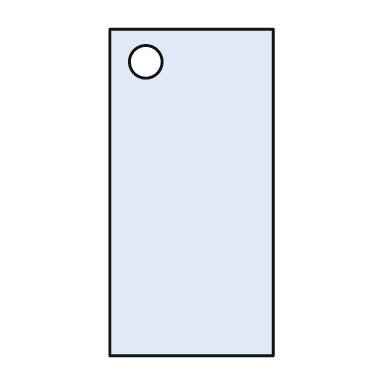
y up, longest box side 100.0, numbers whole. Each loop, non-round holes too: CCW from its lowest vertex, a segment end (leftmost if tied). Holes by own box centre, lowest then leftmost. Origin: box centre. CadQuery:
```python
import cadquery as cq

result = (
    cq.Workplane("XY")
    .moveTo(-25.0, -50.0)
    .lineTo(25.0, -50.0)
    .lineTo(25.0, 50.0)
    .lineTo(-25.0, 50.0)
    .close()
    .moveTo(-14.0, 40.0)
    .circle(5.0)
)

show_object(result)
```